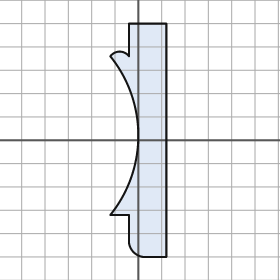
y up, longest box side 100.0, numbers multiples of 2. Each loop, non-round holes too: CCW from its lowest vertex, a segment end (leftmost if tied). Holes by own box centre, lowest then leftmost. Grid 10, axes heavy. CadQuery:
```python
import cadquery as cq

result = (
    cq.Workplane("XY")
    .moveTo(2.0, -50.0)
    .lineTo(12.0, -50.0)
    .lineTo(12.0, 50.0)
    .lineTo(-4.0, 50.0)
    .lineTo(-4.0, 36.0)
    .threePointArc((-8.0, 38.0), (-12.0, 36.0))
    .threePointArc((0.0, 2.0), (-12.0, -32.0))
    .lineTo(-4.0, -32.0)
    .lineTo(-4.0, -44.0)
    .threePointArc((-2.0, -48.0), (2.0, -50.0))
    .close()
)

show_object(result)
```